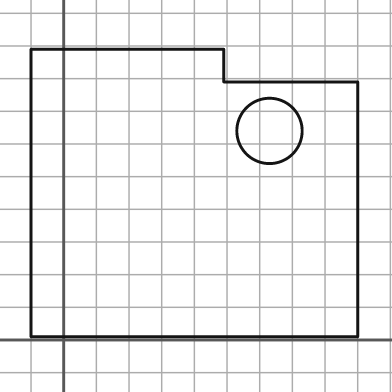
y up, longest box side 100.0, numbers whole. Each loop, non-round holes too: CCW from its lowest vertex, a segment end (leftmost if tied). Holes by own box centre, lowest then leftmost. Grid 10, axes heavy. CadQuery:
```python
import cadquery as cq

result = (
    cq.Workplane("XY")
    .moveTo(-10.0, 1.0)
    .lineTo(90.0, 1.0)
    .lineTo(90.0, 79.0)
    .lineTo(49.0, 79.0)
    .lineTo(49.0, 89.0)
    .lineTo(-10.0, 89.0)
    .close()
    .moveTo(63.0, 64.0)
    .circle(10.0)
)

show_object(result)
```